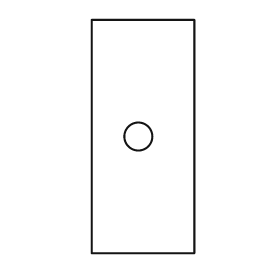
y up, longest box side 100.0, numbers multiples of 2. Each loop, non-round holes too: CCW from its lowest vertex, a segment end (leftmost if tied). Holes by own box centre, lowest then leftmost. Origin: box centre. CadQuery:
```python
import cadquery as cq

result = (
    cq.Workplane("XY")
    .moveTo(-22.0, -50.0)
    .lineTo(22.0, -50.0)
    .lineTo(22.0, 50.0)
    .lineTo(-22.0, 50.0)
    .close()
    .moveTo(-2.0, 0.0)
    .circle(6.0)
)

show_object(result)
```